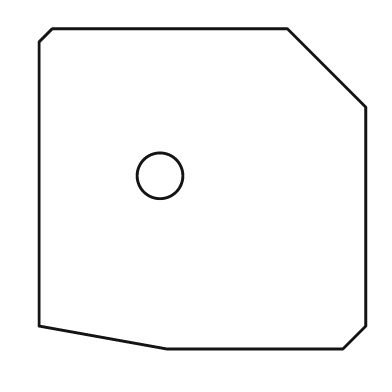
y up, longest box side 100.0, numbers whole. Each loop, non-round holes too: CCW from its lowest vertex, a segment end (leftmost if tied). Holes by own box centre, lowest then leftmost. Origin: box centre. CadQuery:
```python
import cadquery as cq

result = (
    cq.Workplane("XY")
    .moveTo(-11.0, -49.0)
    .lineTo(43.0, -49.0)
    .lineTo(50.0, -42.0)
    .lineTo(50.0, 25.0)
    .lineTo(26.0, 49.0)
    .lineTo(-46.0, 49.0)
    .lineTo(-50.0, 45.0)
    .lineTo(-50.0, -42.0)
    .close()
    .moveTo(-13.0, 4.0)
    .circle(7.0)
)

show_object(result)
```